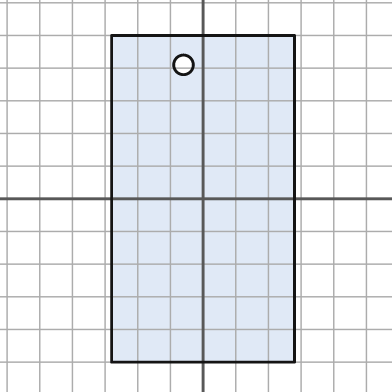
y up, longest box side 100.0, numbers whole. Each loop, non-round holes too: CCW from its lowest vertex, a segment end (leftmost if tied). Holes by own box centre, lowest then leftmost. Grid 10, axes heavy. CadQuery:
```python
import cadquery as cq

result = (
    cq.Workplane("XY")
    .moveTo(-28.0, -50.0)
    .lineTo(28.0, -50.0)
    .lineTo(28.0, 50.0)
    .lineTo(-28.0, 50.0)
    .close()
    .moveTo(-6.0, 41.0)
    .circle(3.0)
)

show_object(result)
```